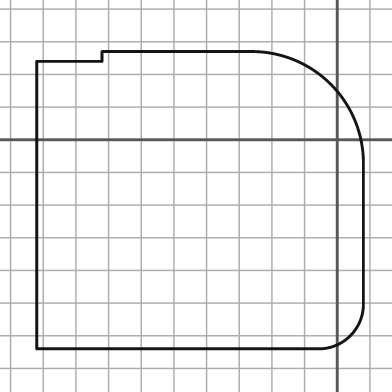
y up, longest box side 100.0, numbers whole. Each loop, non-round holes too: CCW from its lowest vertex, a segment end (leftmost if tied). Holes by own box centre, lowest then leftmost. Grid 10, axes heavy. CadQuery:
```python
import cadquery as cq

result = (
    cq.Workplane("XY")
    .moveTo(-92.0, -64.0)
    .lineTo(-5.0, -64.0)
    .threePointArc((4.0, -60.0), (8.0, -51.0))
    .lineTo(8.0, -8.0)
    .threePointArc((-2.0, 17.0), (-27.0, 27.0))
    .lineTo(-72.0, 27.0)
    .lineTo(-72.0, 24.0)
    .lineTo(-92.0, 24.0)
    .close()
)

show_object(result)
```